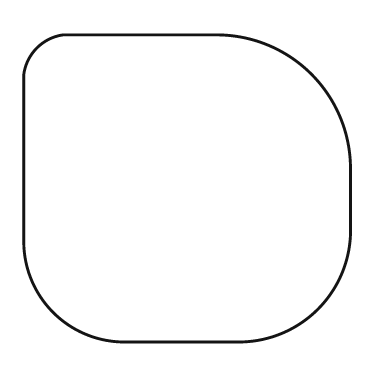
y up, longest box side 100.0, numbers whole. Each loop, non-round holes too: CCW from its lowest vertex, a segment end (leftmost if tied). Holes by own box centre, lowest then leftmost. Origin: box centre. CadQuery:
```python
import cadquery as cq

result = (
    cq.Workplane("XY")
    .moveTo(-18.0, -47.0)
    .lineTo(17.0, -47.0)
    .threePointArc((40.0, -37.0), (50.0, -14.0))
    .lineTo(50.0, 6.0)
    .threePointArc((38.0, 35.0), (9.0, 47.0))
    .lineTo(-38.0, 47.0)
    .threePointArc((-46.0, 43.0), (-50.0, 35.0))
    .lineTo(-50.0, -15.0)
    .threePointArc((-41.0, -38.0), (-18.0, -47.0))
    .close()
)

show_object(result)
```